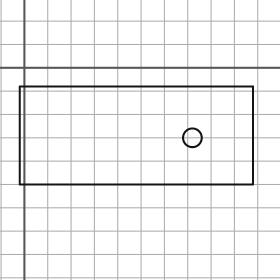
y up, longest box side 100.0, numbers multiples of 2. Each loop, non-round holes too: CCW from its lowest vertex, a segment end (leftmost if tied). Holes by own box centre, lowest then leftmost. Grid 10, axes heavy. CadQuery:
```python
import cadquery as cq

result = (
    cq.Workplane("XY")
    .moveTo(-2.0, -50.0)
    .lineTo(98.0, -50.0)
    .lineTo(98.0, -8.0)
    .lineTo(-2.0, -8.0)
    .close()
    .moveTo(72.0, -30.0)
    .circle(4.0)
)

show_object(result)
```